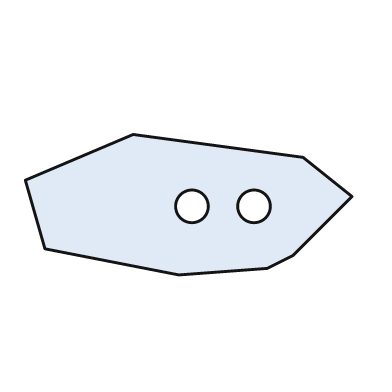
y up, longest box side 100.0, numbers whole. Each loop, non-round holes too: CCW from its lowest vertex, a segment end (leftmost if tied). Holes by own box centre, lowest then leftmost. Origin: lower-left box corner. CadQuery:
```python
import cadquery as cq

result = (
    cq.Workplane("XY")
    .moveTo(47.0, 0.0)
    .lineTo(74.0, 2.0)
    .lineTo(82.0, 6.0)
    .lineTo(100.0, 24.0)
    .lineTo(85.0, 36.0)
    .lineTo(33.0, 43.0)
    .lineTo(0.0, 29.0)
    .lineTo(6.0, 8.0)
    .close()
    .moveTo(51.0, 21.0)
    .circle(5.0)
    .moveTo(70.0, 21.0)
    .circle(5.0)
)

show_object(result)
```